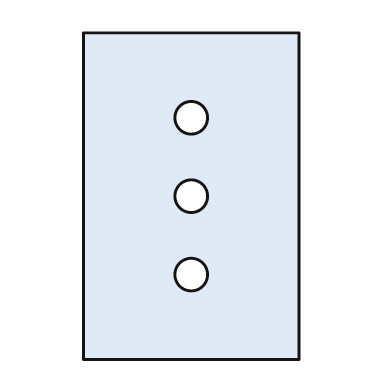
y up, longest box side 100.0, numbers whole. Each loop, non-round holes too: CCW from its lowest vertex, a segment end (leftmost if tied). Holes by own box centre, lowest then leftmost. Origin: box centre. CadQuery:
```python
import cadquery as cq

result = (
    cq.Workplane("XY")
    .moveTo(-33.0, -50.0)
    .lineTo(33.0, -50.0)
    .lineTo(33.0, 50.0)
    .lineTo(-33.0, 50.0)
    .close()
    .moveTo(0.0, -24.0)
    .circle(5.0)
    .moveTo(0.0, 0.0)
    .circle(5.0)
    .moveTo(0.0, 24.0)
    .circle(5.0)
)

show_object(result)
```